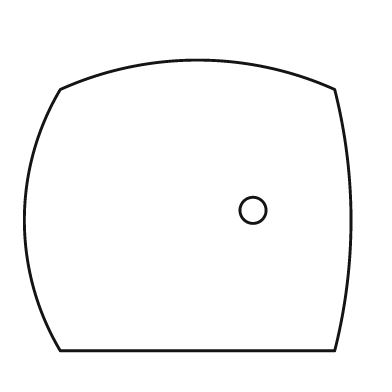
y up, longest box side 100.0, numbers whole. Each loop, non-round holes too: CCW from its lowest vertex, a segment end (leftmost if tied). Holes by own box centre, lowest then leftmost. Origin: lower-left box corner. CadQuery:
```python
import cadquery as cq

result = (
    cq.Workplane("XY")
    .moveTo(11.0, 0.0)
    .lineTo(95.0, 0.0)
    .threePointArc((100.0, 40.0), (95.0, 80.0))
    .threePointArc((53.0, 89.0), (11.0, 80.0))
    .threePointArc((0.0, 40.0), (11.0, 0.0))
    .close()
    .moveTo(70.0, 43.0)
    .circle(4.0)
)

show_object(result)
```